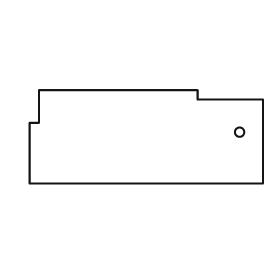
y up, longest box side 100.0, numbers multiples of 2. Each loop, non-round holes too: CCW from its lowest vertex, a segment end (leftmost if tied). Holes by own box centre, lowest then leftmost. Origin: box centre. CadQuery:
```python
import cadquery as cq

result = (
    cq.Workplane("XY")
    .moveTo(-50.0, -20.0)
    .lineTo(50.0, -20.0)
    .lineTo(50.0, 16.0)
    .lineTo(22.0, 16.0)
    .lineTo(22.0, 20.0)
    .lineTo(-46.0, 20.0)
    .lineTo(-46.0, 6.0)
    .lineTo(-50.0, 6.0)
    .close()
    .moveTo(40.0, 2.0)
    .circle(2.0)
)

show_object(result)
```